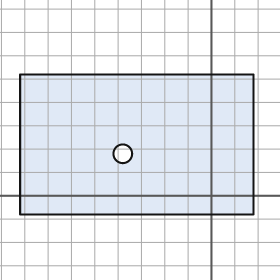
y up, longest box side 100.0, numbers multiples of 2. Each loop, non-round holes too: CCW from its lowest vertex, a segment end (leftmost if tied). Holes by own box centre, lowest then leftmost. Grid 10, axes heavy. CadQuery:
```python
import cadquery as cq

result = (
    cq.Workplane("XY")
    .moveTo(-82.0, -8.0)
    .lineTo(18.0, -8.0)
    .lineTo(18.0, 52.0)
    .lineTo(-82.0, 52.0)
    .close()
    .moveTo(-38.0, 18.0)
    .circle(4.0)
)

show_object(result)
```